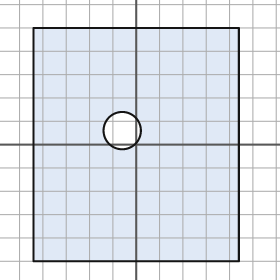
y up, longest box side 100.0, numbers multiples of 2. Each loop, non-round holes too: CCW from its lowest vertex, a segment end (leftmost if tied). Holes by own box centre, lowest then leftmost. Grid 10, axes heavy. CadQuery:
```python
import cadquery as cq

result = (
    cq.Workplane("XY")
    .moveTo(-44.0, -50.0)
    .lineTo(44.0, -50.0)
    .lineTo(44.0, 50.0)
    .lineTo(-44.0, 50.0)
    .close()
    .moveTo(-6.0, 6.0)
    .circle(8.0)
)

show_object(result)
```